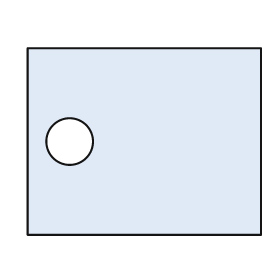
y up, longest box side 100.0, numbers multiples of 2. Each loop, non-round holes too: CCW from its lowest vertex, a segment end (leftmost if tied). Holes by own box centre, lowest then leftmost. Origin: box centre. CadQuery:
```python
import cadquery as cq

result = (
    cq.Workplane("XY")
    .moveTo(-50.0, -40.0)
    .lineTo(50.0, -40.0)
    .lineTo(50.0, 40.0)
    .lineTo(-50.0, 40.0)
    .close()
    .moveTo(-32.0, 0.0)
    .circle(10.0)
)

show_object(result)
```